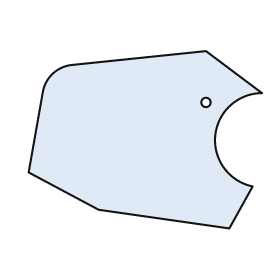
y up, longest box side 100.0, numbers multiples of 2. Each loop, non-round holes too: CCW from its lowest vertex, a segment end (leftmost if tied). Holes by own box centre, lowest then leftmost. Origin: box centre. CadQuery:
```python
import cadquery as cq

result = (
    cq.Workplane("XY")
    .moveTo(36.0, -38.0)
    .lineTo(46.0, -20.0)
    .threePointArc((30.0, 2.0), (50.0, 20.0))
    .lineTo(26.0, 38.0)
    .lineTo(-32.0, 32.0)
    .threePointArc((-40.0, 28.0), (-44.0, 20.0))
    .lineTo(-50.0, -14.0)
    .lineTo(-20.0, -30.0)
    .close()
    .moveTo(26.0, 16.0)
    .circle(2.0)
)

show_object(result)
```